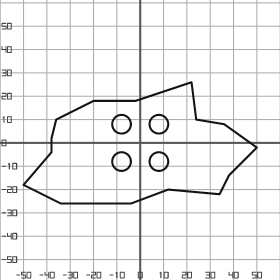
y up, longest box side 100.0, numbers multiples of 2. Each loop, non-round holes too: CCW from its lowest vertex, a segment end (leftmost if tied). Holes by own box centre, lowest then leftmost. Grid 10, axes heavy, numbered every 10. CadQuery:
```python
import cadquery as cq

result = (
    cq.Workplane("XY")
    .moveTo(-34.0, -26.0)
    .lineTo(-4.0, -26.0)
    .lineTo(12.0, -20.0)
    .lineTo(34.0, -22.0)
    .lineTo(38.0, -14.0)
    .lineTo(50.0, -2.0)
    .lineTo(36.0, 8.0)
    .lineTo(24.0, 10.0)
    .lineTo(22.0, 26.0)
    .lineTo(-2.0, 18.0)
    .lineTo(-20.0, 18.0)
    .lineTo(-36.0, 10.0)
    .lineTo(-38.0, 2.0)
    .lineTo(-38.0, -4.0)
    .lineTo(-50.0, -18.0)
    .close()
    .moveTo(-8.0, -8.0)
    .circle(4.0)
    .moveTo(8.0, -8.0)
    .circle(4.0)
    .moveTo(-8.0, 8.0)
    .circle(4.0)
    .moveTo(8.0, 8.0)
    .circle(4.0)
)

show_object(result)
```